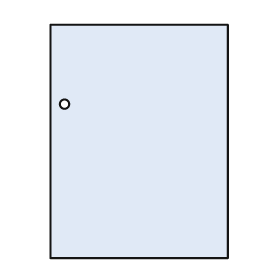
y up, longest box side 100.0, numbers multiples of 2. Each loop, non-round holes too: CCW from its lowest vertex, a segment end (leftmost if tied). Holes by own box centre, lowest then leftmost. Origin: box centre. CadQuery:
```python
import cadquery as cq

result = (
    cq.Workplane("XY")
    .moveTo(-38.0, -50.0)
    .lineTo(38.0, -50.0)
    .lineTo(38.0, 50.0)
    .lineTo(-38.0, 50.0)
    .close()
    .moveTo(-32.0, 16.0)
    .circle(2.0)
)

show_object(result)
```